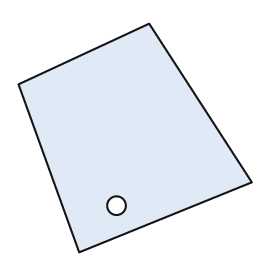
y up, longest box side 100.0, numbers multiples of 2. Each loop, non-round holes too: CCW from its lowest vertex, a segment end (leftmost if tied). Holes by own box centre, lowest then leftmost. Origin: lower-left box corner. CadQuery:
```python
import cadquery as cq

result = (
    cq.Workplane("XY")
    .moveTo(26.0, 0.0)
    .lineTo(100.0, 30.0)
    .lineTo(56.0, 98.0)
    .lineTo(0.0, 72.0)
    .close()
    .moveTo(42.0, 20.0)
    .circle(4.0)
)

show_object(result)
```